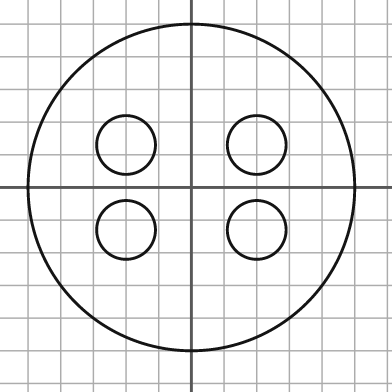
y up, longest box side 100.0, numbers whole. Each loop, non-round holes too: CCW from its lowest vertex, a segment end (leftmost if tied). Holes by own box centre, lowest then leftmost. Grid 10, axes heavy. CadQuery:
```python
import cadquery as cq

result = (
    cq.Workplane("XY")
    .moveTo(0.0, 0.0)
    .circle(50.0)
    .moveTo(-20.0, -13.0)
    .circle(9.0)
    .moveTo(20.0, -13.0)
    .circle(9.0)
    .moveTo(-20.0, 13.0)
    .circle(9.0)
    .moveTo(20.0, 13.0)
    .circle(9.0)
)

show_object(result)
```